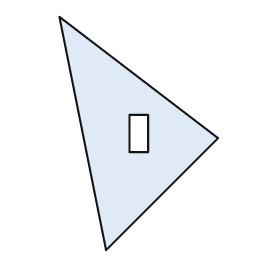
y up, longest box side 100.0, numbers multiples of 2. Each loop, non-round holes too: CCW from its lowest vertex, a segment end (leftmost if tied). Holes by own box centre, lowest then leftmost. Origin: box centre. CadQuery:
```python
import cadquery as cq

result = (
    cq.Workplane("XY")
    .moveTo(-14.0, -50.0)
    .lineTo(34.0, -2.0)
    .lineTo(-34.0, 50.0)
    .close()
    .moveTo(-4.0, -8.0)
    .lineTo(4.0, -8.0)
    .lineTo(4.0, 8.0)
    .lineTo(-4.0, 8.0)
    .close()
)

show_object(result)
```